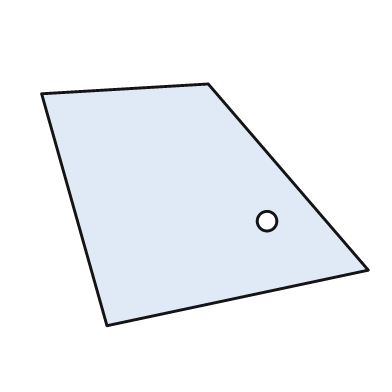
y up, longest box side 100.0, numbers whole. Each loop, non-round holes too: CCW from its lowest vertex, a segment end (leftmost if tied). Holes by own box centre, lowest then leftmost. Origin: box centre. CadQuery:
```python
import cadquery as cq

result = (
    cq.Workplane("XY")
    .moveTo(-30.0, -37.0)
    .lineTo(50.0, -20.0)
    .lineTo(1.0, 37.0)
    .lineTo(-50.0, 34.0)
    .close()
    .moveTo(19.0, -5.0)
    .circle(3.0)
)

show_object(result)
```